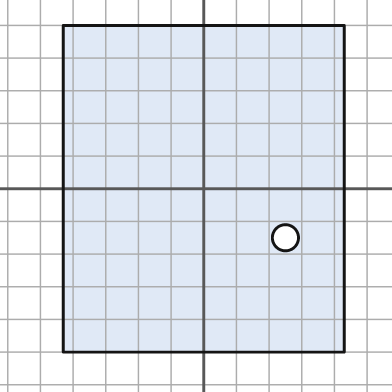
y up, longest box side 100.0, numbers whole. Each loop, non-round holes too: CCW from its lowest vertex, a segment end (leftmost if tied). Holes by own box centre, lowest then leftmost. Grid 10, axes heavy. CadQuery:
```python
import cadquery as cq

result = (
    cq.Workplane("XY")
    .moveTo(-43.0, -50.0)
    .lineTo(43.0, -50.0)
    .lineTo(43.0, 50.0)
    .lineTo(-43.0, 50.0)
    .close()
    .moveTo(25.0, -15.0)
    .circle(4.0)
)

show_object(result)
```